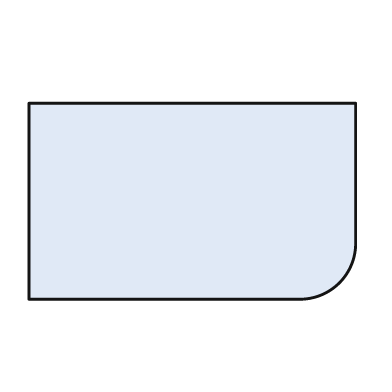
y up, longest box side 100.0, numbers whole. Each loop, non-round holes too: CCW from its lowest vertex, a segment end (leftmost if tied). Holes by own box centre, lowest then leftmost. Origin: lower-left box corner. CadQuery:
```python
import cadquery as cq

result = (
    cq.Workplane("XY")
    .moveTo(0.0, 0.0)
    .lineTo(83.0, 0.0)
    .threePointArc((95.0, 5.0), (100.0, 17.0))
    .lineTo(100.0, 60.0)
    .lineTo(0.0, 60.0)
    .close()
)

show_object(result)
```